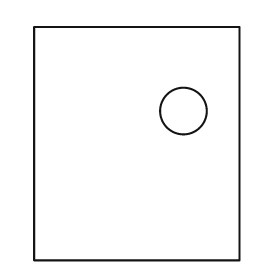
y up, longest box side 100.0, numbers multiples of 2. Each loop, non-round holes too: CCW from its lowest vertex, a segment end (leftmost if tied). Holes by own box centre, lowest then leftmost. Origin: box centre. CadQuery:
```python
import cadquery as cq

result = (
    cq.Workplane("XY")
    .moveTo(-44.0, -50.0)
    .lineTo(44.0, -50.0)
    .lineTo(44.0, 50.0)
    .lineTo(-44.0, 50.0)
    .close()
    .moveTo(20.0, 14.0)
    .circle(10.0)
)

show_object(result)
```